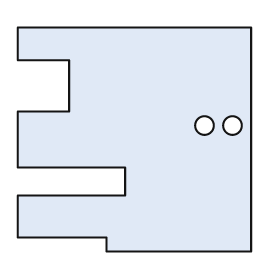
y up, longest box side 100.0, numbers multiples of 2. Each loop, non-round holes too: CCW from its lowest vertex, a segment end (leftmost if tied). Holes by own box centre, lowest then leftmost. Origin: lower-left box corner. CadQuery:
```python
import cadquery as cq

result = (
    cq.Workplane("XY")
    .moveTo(38.0, 0.0)
    .lineTo(100.0, 0.0)
    .lineTo(100.0, 96.0)
    .lineTo(0.0, 96.0)
    .lineTo(0.0, 82.0)
    .lineTo(22.0, 82.0)
    .lineTo(22.0, 60.0)
    .lineTo(0.0, 60.0)
    .lineTo(0.0, 36.0)
    .lineTo(46.0, 36.0)
    .lineTo(46.0, 24.0)
    .lineTo(0.0, 24.0)
    .lineTo(0.0, 6.0)
    .lineTo(38.0, 6.0)
    .close()
    .moveTo(80.0, 54.0)
    .circle(4.0)
    .moveTo(92.0, 54.0)
    .circle(4.0)
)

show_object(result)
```